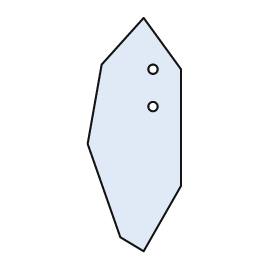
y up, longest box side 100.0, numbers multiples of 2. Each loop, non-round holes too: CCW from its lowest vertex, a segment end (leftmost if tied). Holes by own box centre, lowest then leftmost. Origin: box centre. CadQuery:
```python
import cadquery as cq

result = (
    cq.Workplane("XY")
    .moveTo(4.0, -50.0)
    .lineTo(20.0, -22.0)
    .lineTo(20.0, 28.0)
    .lineTo(4.0, 50.0)
    .lineTo(-14.0, 30.0)
    .lineTo(-20.0, -4.0)
    .lineTo(-6.0, -44.0)
    .close()
    .moveTo(8.0, 12.0)
    .circle(2.0)
    .moveTo(8.0, 28.0)
    .circle(2.0)
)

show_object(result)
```